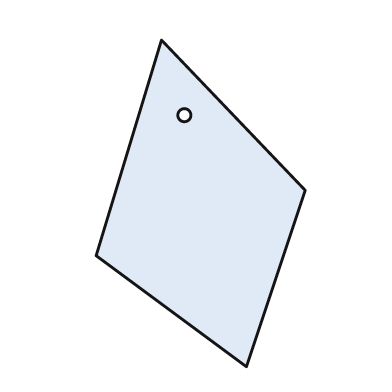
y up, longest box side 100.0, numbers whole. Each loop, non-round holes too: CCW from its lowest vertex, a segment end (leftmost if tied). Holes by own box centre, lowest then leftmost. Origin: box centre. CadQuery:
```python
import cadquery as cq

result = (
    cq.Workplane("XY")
    .moveTo(14.0, -50.0)
    .lineTo(32.0, 4.0)
    .lineTo(-12.0, 50.0)
    .lineTo(-32.0, -16.0)
    .close()
    .moveTo(-5.0, 27.0)
    .circle(2.0)
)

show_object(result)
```